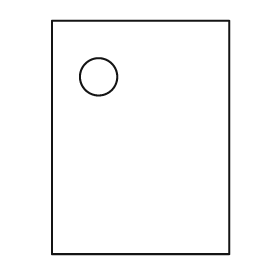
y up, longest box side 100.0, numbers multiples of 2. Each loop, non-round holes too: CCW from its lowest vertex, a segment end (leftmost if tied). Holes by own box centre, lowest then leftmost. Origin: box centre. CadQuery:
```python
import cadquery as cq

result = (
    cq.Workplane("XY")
    .moveTo(-38.0, -50.0)
    .lineTo(38.0, -50.0)
    .lineTo(38.0, 50.0)
    .lineTo(-38.0, 50.0)
    .close()
    .moveTo(-18.0, 26.0)
    .circle(8.0)
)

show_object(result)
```